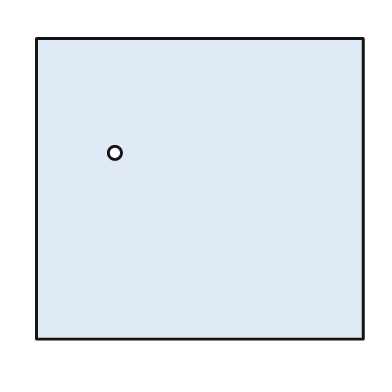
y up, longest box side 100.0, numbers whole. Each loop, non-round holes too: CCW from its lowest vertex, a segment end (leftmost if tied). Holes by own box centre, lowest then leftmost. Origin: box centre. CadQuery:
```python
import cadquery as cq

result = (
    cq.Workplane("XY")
    .moveTo(-50.0, -46.0)
    .lineTo(50.0, -46.0)
    .lineTo(50.0, 46.0)
    .lineTo(-50.0, 46.0)
    .close()
    .moveTo(-26.0, 11.0)
    .circle(2.0)
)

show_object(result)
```